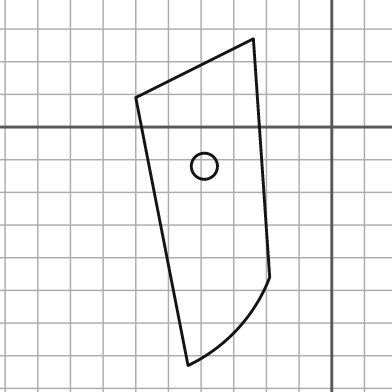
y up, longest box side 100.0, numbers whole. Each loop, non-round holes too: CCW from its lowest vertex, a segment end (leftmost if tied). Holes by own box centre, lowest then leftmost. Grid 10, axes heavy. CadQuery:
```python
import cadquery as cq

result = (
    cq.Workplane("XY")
    .moveTo(-44.0, -73.0)
    .threePointArc((-29.0, -62.0), (-19.0, -46.0))
    .lineTo(-24.0, 27.0)
    .lineTo(-60.0, 9.0)
    .close()
    .moveTo(-39.0, -12.0)
    .circle(4.0)
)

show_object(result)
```